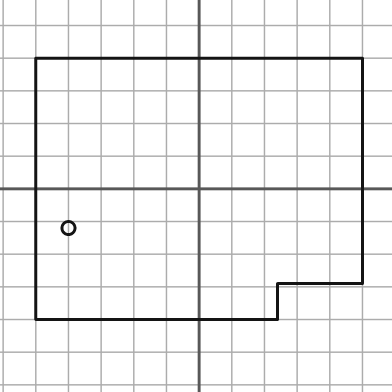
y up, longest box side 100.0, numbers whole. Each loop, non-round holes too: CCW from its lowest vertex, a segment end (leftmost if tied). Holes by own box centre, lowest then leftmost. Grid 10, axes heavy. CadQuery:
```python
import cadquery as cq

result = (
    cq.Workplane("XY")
    .moveTo(-50.0, -40.0)
    .lineTo(24.0, -40.0)
    .lineTo(24.0, -29.0)
    .lineTo(50.0, -29.0)
    .lineTo(50.0, 40.0)
    .lineTo(-50.0, 40.0)
    .close()
    .moveTo(-40.0, -12.0)
    .circle(2.0)
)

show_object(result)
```